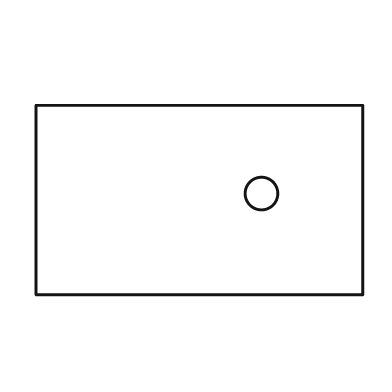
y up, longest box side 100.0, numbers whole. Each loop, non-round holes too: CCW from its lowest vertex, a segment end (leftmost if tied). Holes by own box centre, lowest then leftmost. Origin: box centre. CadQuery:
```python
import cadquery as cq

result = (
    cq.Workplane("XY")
    .moveTo(-50.0, -29.0)
    .lineTo(50.0, -29.0)
    .lineTo(50.0, 29.0)
    .lineTo(-50.0, 29.0)
    .close()
    .moveTo(19.0, 2.0)
    .circle(5.0)
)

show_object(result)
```